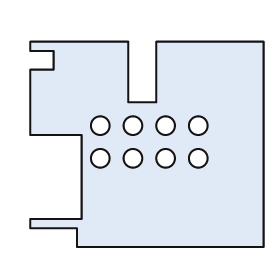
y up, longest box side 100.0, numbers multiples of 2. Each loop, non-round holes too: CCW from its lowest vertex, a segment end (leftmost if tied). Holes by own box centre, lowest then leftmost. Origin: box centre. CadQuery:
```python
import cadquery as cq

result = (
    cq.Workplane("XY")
    .moveTo(-30.0, -44.0)
    .lineTo(50.0, -44.0)
    .lineTo(50.0, 44.0)
    .lineTo(4.0, 44.0)
    .lineTo(4.0, 18.0)
    .lineTo(-8.0, 18.0)
    .lineTo(-8.0, 44.0)
    .lineTo(-50.0, 44.0)
    .lineTo(-50.0, 40.0)
    .lineTo(-40.0, 40.0)
    .lineTo(-40.0, 32.0)
    .lineTo(-50.0, 32.0)
    .lineTo(-50.0, 4.0)
    .lineTo(-28.0, 4.0)
    .lineTo(-28.0, -32.0)
    .lineTo(-50.0, -32.0)
    .lineTo(-50.0, -36.0)
    .lineTo(-30.0, -36.0)
    .close()
    .moveTo(-20.0, -6.0)
    .circle(4.0)
    .moveTo(-6.0, -6.0)
    .circle(4.0)
    .moveTo(8.0, -6.0)
    .circle(4.0)
    .moveTo(22.0, -6.0)
    .circle(4.0)
    .moveTo(-20.0, 8.0)
    .circle(4.0)
    .moveTo(-6.0, 8.0)
    .circle(4.0)
    .moveTo(8.0, 8.0)
    .circle(4.0)
    .moveTo(22.0, 8.0)
    .circle(4.0)
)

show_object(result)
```